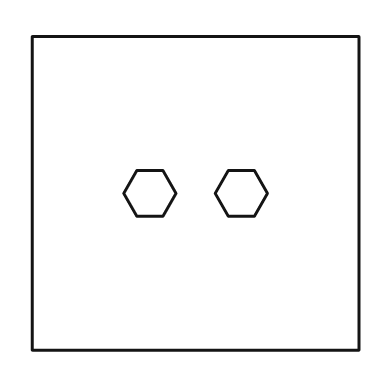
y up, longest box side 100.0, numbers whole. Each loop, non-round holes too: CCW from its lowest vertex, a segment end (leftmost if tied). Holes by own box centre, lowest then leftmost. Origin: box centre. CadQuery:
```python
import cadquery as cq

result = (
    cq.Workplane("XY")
    .moveTo(-50.0, -48.0)
    .lineTo(50.0, -48.0)
    .lineTo(50.0, 48.0)
    .lineTo(-50.0, 48.0)
    .close()
    .moveTo(-18.0, -7.0)
    .lineTo(-10.0, -7.0)
    .lineTo(-6.0, 0.0)
    .lineTo(-10.0, 7.0)
    .lineTo(-18.0, 7.0)
    .lineTo(-22.0, 0.0)
    .close()
    .moveTo(10.0, -7.0)
    .lineTo(18.0, -7.0)
    .lineTo(22.0, 0.0)
    .lineTo(18.0, 7.0)
    .lineTo(10.0, 7.0)
    .lineTo(6.0, 0.0)
    .close()
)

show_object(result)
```